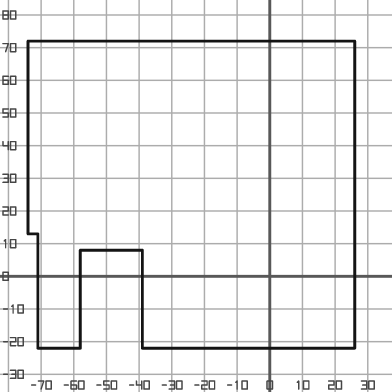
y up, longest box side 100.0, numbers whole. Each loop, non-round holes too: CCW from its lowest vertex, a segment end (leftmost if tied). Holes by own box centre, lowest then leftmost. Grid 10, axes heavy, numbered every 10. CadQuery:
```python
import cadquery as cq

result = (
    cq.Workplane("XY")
    .moveTo(-71.0, -22.0)
    .lineTo(-58.0, -22.0)
    .lineTo(-58.0, 8.0)
    .lineTo(-39.0, 8.0)
    .lineTo(-39.0, -22.0)
    .lineTo(26.0, -22.0)
    .lineTo(26.0, 72.0)
    .lineTo(-74.0, 72.0)
    .lineTo(-74.0, 13.0)
    .lineTo(-71.0, 13.0)
    .close()
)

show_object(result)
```